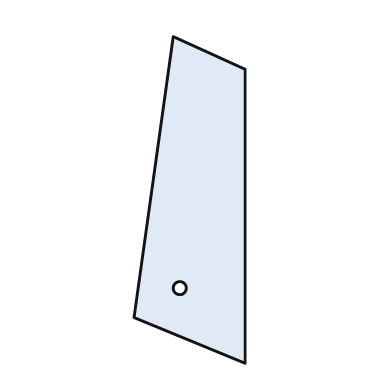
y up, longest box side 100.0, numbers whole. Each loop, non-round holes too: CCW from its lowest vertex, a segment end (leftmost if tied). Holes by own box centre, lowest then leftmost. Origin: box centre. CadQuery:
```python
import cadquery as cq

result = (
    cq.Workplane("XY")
    .moveTo(17.0, -50.0)
    .lineTo(17.0, 40.0)
    .lineTo(-5.0, 50.0)
    .lineTo(-17.0, -36.0)
    .close()
    .moveTo(-3.0, -27.0)
    .circle(2.0)
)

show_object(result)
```